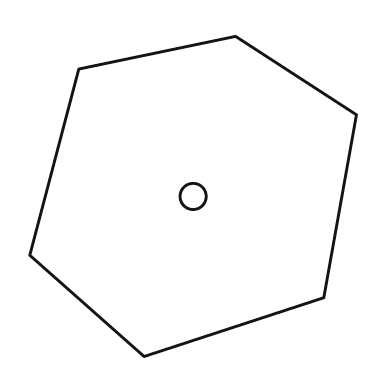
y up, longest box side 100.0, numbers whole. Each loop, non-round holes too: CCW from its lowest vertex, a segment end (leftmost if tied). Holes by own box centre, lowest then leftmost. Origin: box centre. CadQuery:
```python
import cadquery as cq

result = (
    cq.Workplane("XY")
    .moveTo(-15.0, -49.0)
    .lineTo(40.0, -31.0)
    .lineTo(50.0, 25.0)
    .lineTo(13.0, 49.0)
    .lineTo(-35.0, 39.0)
    .lineTo(-50.0, -18.0)
    .close()
    .moveTo(0.0, 0.0)
    .circle(4.0)
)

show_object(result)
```